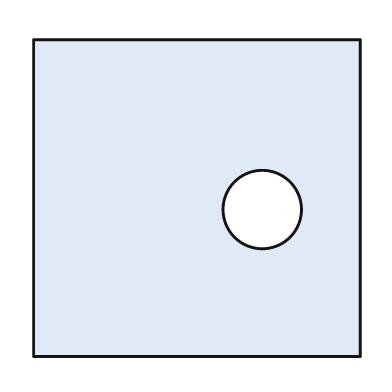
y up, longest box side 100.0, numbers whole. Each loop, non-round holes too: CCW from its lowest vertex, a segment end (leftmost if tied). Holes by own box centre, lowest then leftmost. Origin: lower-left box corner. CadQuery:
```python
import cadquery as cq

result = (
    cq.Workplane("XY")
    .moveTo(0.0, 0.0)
    .lineTo(100.0, 0.0)
    .lineTo(100.0, 97.0)
    .lineTo(0.0, 97.0)
    .close()
    .moveTo(70.0, 45.0)
    .circle(12.0)
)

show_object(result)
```